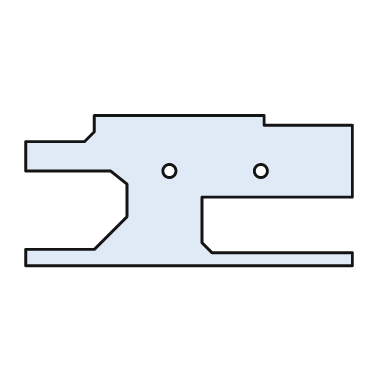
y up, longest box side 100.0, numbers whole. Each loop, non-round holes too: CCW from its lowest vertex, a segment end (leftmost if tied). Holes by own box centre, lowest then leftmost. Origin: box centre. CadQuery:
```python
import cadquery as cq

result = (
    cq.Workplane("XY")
    .moveTo(-50.0, -23.0)
    .lineTo(50.0, -23.0)
    .lineTo(50.0, -19.0)
    .lineTo(7.0, -19.0)
    .lineTo(4.0, -16.0)
    .lineTo(4.0, -2.0)
    .lineTo(50.0, -2.0)
    .lineTo(50.0, 20.0)
    .lineTo(23.0, 20.0)
    .lineTo(23.0, 23.0)
    .lineTo(-29.0, 23.0)
    .lineTo(-29.0, 18.0)
    .lineTo(-32.0, 15.0)
    .lineTo(-50.0, 15.0)
    .lineTo(-50.0, 6.0)
    .lineTo(-24.0, 6.0)
    .lineTo(-19.0, 2.0)
    .lineTo(-19.0, -8.0)
    .lineTo(-29.0, -18.0)
    .lineTo(-50.0, -18.0)
    .close()
    .moveTo(-6.0, 6.0)
    .circle(2.0)
    .moveTo(22.0, 6.0)
    .circle(2.0)
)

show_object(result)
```